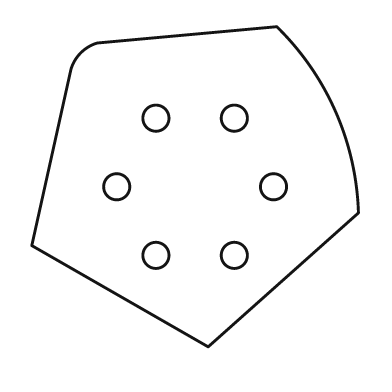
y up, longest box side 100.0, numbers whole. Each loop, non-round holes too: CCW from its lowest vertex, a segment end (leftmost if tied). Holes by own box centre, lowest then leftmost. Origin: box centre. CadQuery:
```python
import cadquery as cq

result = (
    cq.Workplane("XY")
    .moveTo(4.0, -49.0)
    .lineTo(50.0, -8.0)
    .threePointArc((43.0, 23.0), (25.0, 49.0))
    .lineTo(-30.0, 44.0)
    .threePointArc((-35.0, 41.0), (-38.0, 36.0))
    .lineTo(-50.0, -18.0)
    .close()
    .moveTo(-12.0, -21.0)
    .circle(4.0)
    .moveTo(12.0, -21.0)
    .circle(4.0)
    .moveTo(-24.0, 0.0)
    .circle(4.0)
    .moveTo(24.0, 0.0)
    .circle(4.0)
    .moveTo(-12.0, 21.0)
    .circle(4.0)
    .moveTo(12.0, 21.0)
    .circle(4.0)
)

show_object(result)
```